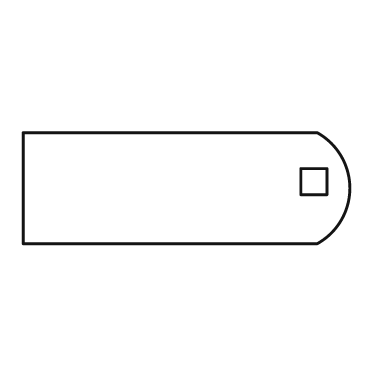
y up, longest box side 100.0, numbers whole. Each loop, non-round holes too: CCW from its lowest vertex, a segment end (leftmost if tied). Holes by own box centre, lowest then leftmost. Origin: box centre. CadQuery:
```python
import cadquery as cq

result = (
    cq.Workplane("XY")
    .moveTo(-50.0, -17.0)
    .lineTo(40.0, -17.0)
    .threePointArc((50.0, 0.0), (40.0, 17.0))
    .lineTo(-50.0, 17.0)
    .close()
    .moveTo(35.0, -2.0)
    .lineTo(43.0, -2.0)
    .lineTo(43.0, 6.0)
    .lineTo(35.0, 6.0)
    .close()
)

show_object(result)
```